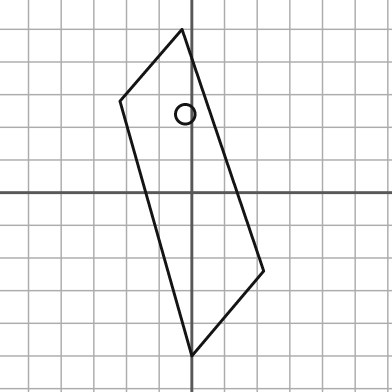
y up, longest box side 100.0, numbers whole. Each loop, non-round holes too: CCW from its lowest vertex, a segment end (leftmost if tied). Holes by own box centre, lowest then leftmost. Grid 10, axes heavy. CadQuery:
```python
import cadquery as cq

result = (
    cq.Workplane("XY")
    .moveTo(0.0, -50.0)
    .lineTo(22.0, -24.0)
    .lineTo(-3.0, 50.0)
    .lineTo(-22.0, 28.0)
    .close()
    .moveTo(-2.0, 24.0)
    .circle(3.0)
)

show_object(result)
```